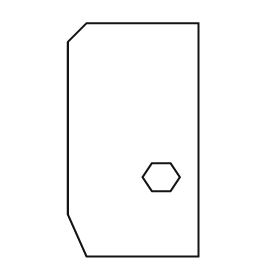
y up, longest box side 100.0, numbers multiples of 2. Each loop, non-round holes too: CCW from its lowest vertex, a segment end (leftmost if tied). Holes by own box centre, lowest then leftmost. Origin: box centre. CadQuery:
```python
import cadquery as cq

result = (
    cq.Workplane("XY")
    .moveTo(-20.0, -50.0)
    .lineTo(28.0, -50.0)
    .lineTo(28.0, 50.0)
    .lineTo(-20.0, 50.0)
    .lineTo(-28.0, 42.0)
    .lineTo(-28.0, -32.0)
    .close()
    .moveTo(8.0, -22.0)
    .lineTo(16.0, -22.0)
    .lineTo(20.0, -16.0)
    .lineTo(16.0, -10.0)
    .lineTo(8.0, -10.0)
    .lineTo(4.0, -16.0)
    .close()
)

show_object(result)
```